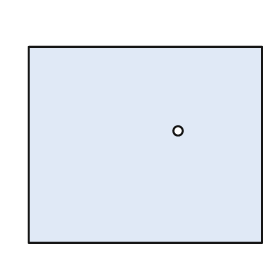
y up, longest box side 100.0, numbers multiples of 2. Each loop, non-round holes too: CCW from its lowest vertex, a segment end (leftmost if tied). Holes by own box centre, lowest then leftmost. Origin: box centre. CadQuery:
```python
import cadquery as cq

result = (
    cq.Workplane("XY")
    .moveTo(-50.0, -42.0)
    .lineTo(50.0, -42.0)
    .lineTo(50.0, 42.0)
    .lineTo(-50.0, 42.0)
    .close()
    .moveTo(14.0, 6.0)
    .circle(2.0)
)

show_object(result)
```